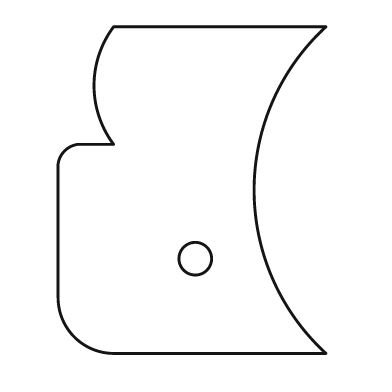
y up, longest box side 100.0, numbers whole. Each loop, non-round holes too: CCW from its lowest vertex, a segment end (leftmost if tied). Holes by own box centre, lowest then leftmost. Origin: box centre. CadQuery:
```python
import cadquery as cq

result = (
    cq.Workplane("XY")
    .moveTo(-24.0, -50.0)
    .lineTo(41.0, -50.0)
    .threePointArc((19.0, 0.0), (41.0, 50.0))
    .lineTo(-24.0, 50.0)
    .threePointArc((-30.0, 32.0), (-24.0, 14.0))
    .lineTo(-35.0, 14.0)
    .threePointArc((-39.0, 12.0), (-41.0, 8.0))
    .lineTo(-41.0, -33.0)
    .threePointArc((-36.0, -45.0), (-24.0, -50.0))
    .close()
    .moveTo(1.0, -21.0)
    .circle(5.0)
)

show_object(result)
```